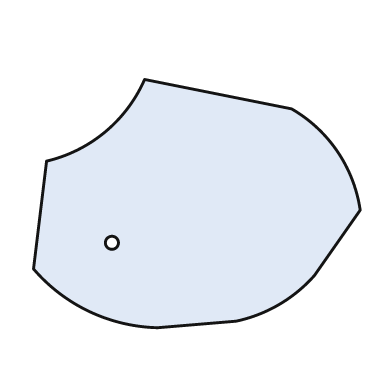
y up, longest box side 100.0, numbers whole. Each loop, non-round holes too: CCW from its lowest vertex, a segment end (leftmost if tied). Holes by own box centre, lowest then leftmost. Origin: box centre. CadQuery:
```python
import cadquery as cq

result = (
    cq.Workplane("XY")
    .moveTo(-12.0, -38.0)
    .lineTo(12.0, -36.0)
    .threePointArc((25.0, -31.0), (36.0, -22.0))
    .lineTo(50.0, -2.0)
    .threePointArc((43.0, 16.0), (29.0, 29.0))
    .lineTo(-16.0, 38.0)
    .threePointArc((-28.0, 22.0), (-46.0, 13.0))
    .lineTo(-50.0, -20.0)
    .threePointArc((-33.0, -33.0), (-12.0, -38.0))
    .close()
    .moveTo(-26.0, -12.0)
    .circle(2.0)
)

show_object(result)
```